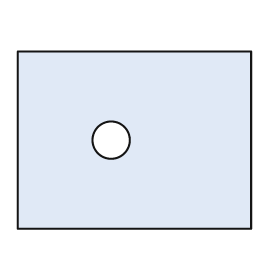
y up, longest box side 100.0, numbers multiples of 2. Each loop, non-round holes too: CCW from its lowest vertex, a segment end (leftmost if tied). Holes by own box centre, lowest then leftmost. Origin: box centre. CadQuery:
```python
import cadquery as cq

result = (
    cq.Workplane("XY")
    .moveTo(-50.0, -38.0)
    .lineTo(50.0, -38.0)
    .lineTo(50.0, 38.0)
    .lineTo(-50.0, 38.0)
    .close()
    .moveTo(-10.0, 0.0)
    .circle(8.0)
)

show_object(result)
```